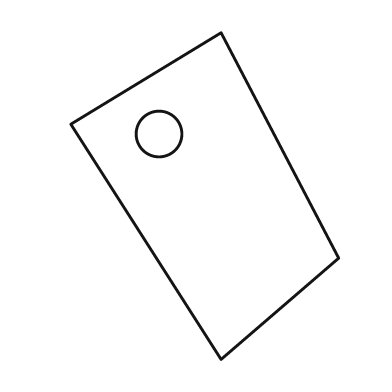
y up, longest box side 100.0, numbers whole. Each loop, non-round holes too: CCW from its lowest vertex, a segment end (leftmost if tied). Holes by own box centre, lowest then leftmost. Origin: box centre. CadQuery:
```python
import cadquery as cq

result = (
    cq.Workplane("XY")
    .moveTo(5.0, -50.0)
    .lineTo(41.0, -19.0)
    .lineTo(5.0, 50.0)
    .lineTo(-41.0, 22.0)
    .close()
    .moveTo(-14.0, 19.0)
    .circle(7.0)
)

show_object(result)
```